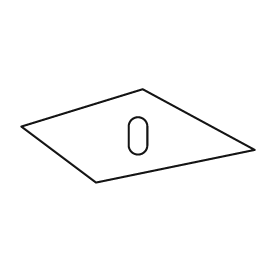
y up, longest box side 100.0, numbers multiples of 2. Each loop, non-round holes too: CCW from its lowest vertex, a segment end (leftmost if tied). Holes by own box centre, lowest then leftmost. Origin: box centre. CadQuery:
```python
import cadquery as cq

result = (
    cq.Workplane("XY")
    .moveTo(-18.0, -20.0)
    .lineTo(50.0, -6.0)
    .lineTo(2.0, 20.0)
    .lineTo(-50.0, 4.0)
    .close()
    .moveTo(-4.0, -4.0)
    .threePointArc((0.0, -8.0), (4.0, -4.0))
    .lineTo(4.0, 4.0)
    .threePointArc((0.0, 8.0), (-4.0, 4.0))
    .close()
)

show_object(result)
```